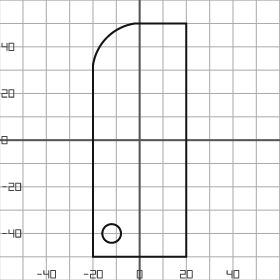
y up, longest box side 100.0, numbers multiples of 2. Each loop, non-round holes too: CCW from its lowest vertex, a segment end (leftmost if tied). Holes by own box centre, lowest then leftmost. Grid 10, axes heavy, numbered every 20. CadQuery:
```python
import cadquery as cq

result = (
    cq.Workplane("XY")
    .moveTo(-20.0, -50.0)
    .lineTo(20.0, -50.0)
    .lineTo(20.0, 50.0)
    .lineTo(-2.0, 50.0)
    .threePointArc((-14.0, 44.0), (-20.0, 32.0))
    .close()
    .moveTo(-12.0, -40.0)
    .circle(4.0)
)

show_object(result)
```